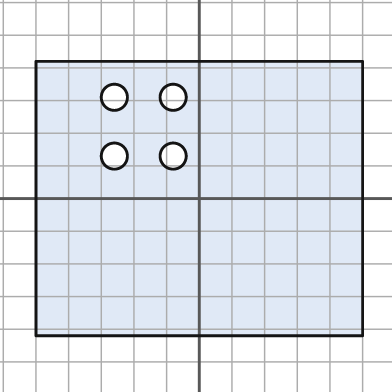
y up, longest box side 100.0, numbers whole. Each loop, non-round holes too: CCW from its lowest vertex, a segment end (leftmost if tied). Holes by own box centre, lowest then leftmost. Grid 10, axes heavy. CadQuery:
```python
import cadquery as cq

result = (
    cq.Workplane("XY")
    .moveTo(-50.0, -42.0)
    .lineTo(50.0, -42.0)
    .lineTo(50.0, 42.0)
    .lineTo(-50.0, 42.0)
    .close()
    .moveTo(-26.0, 13.0)
    .circle(4.0)
    .moveTo(-8.0, 13.0)
    .circle(4.0)
    .moveTo(-26.0, 31.0)
    .circle(4.0)
    .moveTo(-8.0, 31.0)
    .circle(4.0)
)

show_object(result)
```